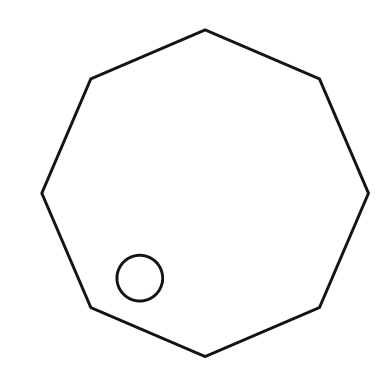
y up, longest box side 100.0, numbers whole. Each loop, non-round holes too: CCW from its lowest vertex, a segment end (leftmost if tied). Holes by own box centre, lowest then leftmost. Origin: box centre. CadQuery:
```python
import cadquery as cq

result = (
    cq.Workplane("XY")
    .moveTo(0.0, -50.0)
    .lineTo(35.0, -35.0)
    .lineTo(50.0, 0.0)
    .lineTo(35.0, 35.0)
    .lineTo(0.0, 50.0)
    .lineTo(-35.0, 35.0)
    .lineTo(-50.0, 0.0)
    .lineTo(-35.0, -35.0)
    .close()
    .moveTo(-20.0, -26.0)
    .circle(7.0)
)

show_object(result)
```